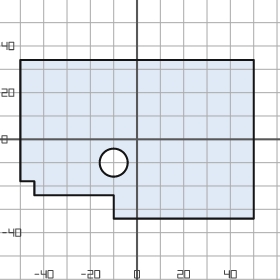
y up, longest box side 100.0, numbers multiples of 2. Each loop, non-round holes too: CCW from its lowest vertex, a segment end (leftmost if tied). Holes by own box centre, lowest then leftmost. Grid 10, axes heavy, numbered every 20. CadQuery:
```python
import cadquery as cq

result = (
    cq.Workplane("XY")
    .moveTo(-10.0, -34.0)
    .lineTo(50.0, -34.0)
    .lineTo(50.0, 34.0)
    .lineTo(-50.0, 34.0)
    .lineTo(-50.0, -18.0)
    .lineTo(-44.0, -18.0)
    .lineTo(-44.0, -24.0)
    .lineTo(-10.0, -24.0)
    .close()
    .moveTo(-10.0, -10.0)
    .circle(6.0)
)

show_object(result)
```